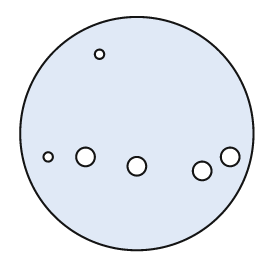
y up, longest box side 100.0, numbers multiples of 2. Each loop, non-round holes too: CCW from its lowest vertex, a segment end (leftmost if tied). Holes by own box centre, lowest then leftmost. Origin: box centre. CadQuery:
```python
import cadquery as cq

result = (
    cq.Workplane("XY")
    .moveTo(0.0, 0.0)
    .circle(50.0)
    .moveTo(28.0, -16.0)
    .circle(4.0)
    .moveTo(0.0, -14.0)
    .circle(4.0)
    .moveTo(-38.0, -10.0)
    .circle(2.0)
    .moveTo(-22.0, -10.0)
    .circle(4.0)
    .moveTo(40.0, -10.0)
    .circle(4.0)
    .moveTo(-16.0, 34.0)
    .circle(2.0)
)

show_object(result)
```